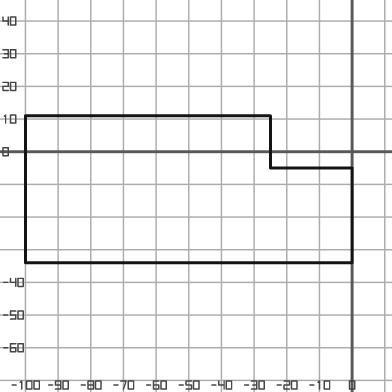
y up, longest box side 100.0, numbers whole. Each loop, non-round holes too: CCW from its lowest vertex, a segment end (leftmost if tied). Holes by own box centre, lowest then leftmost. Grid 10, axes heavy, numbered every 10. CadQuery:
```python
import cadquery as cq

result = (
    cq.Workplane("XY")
    .moveTo(-100.0, -34.0)
    .lineTo(0.0, -34.0)
    .lineTo(0.0, -5.0)
    .lineTo(-25.0, -5.0)
    .lineTo(-25.0, 11.0)
    .lineTo(-100.0, 11.0)
    .close()
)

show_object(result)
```